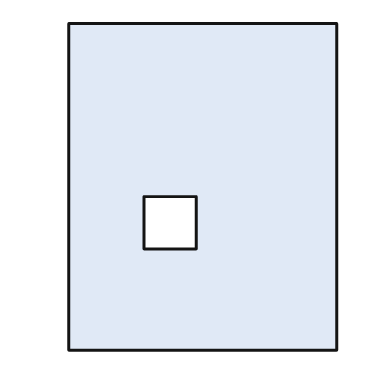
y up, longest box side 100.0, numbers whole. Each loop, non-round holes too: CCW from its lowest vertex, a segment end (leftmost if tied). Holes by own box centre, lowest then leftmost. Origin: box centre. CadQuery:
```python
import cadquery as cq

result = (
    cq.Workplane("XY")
    .moveTo(-41.0, -50.0)
    .lineTo(41.0, -50.0)
    .lineTo(41.0, 50.0)
    .lineTo(-41.0, 50.0)
    .close()
    .moveTo(-18.0, -19.0)
    .lineTo(-2.0, -19.0)
    .lineTo(-2.0, -3.0)
    .lineTo(-18.0, -3.0)
    .close()
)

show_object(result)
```